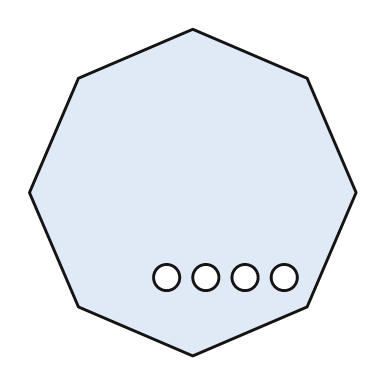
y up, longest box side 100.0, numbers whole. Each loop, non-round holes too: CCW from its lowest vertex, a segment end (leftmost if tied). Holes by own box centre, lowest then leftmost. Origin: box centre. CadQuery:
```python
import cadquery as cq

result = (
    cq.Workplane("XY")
    .moveTo(0.0, -50.0)
    .lineTo(35.0, -35.0)
    .lineTo(50.0, 0.0)
    .lineTo(35.0, 35.0)
    .lineTo(0.0, 50.0)
    .lineTo(-35.0, 35.0)
    .lineTo(-50.0, 0.0)
    .lineTo(-35.0, -35.0)
    .close()
    .moveTo(-8.0, -26.0)
    .circle(4.0)
    .moveTo(4.0, -26.0)
    .circle(4.0)
    .moveTo(16.0, -26.0)
    .circle(4.0)
    .moveTo(28.0, -26.0)
    .circle(4.0)
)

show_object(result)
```